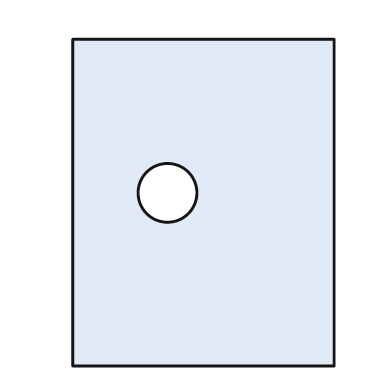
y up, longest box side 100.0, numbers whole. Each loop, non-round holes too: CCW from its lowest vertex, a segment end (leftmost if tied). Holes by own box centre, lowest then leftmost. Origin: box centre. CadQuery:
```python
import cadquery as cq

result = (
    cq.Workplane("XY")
    .moveTo(-40.0, -50.0)
    .lineTo(40.0, -50.0)
    .lineTo(40.0, 50.0)
    .lineTo(-40.0, 50.0)
    .close()
    .moveTo(-11.0, 3.0)
    .circle(9.0)
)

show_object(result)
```